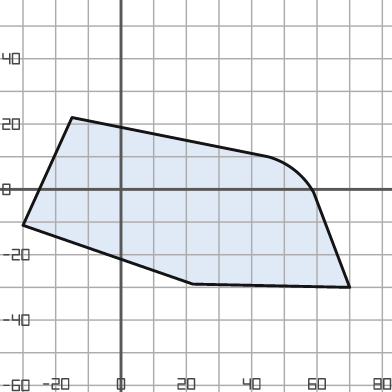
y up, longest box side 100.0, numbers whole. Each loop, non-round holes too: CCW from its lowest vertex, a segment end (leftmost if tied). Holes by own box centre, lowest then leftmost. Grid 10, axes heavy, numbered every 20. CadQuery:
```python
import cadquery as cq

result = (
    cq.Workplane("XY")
    .moveTo(70.0, -30.0)
    .lineTo(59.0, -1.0)
    .threePointArc((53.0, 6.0), (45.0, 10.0))
    .lineTo(-15.0, 22.0)
    .lineTo(-30.0, -11.0)
    .lineTo(22.0, -29.0)
    .close()
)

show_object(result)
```